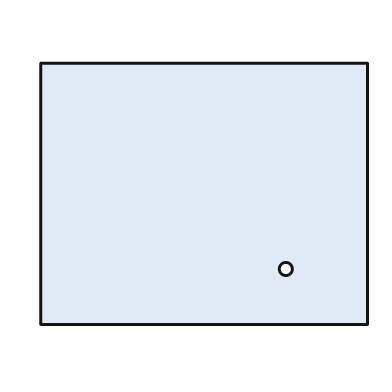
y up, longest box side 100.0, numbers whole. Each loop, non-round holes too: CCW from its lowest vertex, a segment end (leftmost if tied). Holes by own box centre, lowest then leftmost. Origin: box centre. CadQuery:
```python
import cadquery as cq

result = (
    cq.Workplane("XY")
    .moveTo(-50.0, -40.0)
    .lineTo(50.0, -40.0)
    .lineTo(50.0, 40.0)
    .lineTo(-50.0, 40.0)
    .close()
    .moveTo(25.0, -23.0)
    .circle(2.0)
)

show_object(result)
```